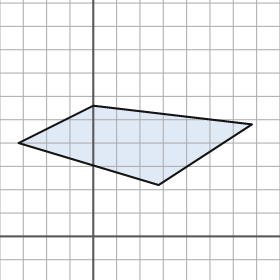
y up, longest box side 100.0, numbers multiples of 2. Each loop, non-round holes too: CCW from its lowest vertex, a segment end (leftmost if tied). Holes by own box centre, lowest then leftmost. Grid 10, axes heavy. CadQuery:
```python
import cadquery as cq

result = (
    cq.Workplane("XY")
    .moveTo(28.0, 22.0)
    .lineTo(68.0, 48.0)
    .lineTo(0.0, 56.0)
    .lineTo(-32.0, 40.0)
    .close()
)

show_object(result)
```